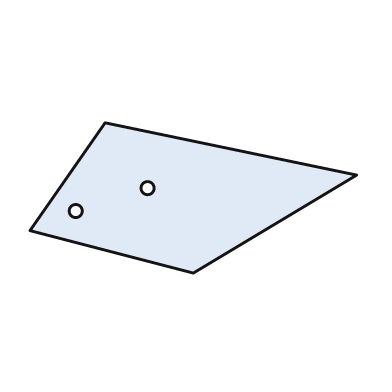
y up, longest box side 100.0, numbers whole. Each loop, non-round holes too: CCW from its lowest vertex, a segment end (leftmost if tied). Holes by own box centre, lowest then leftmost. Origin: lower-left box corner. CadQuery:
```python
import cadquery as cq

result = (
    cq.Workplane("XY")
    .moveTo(50.0, 0.0)
    .lineTo(100.0, 30.0)
    .lineTo(23.0, 46.0)
    .lineTo(0.0, 13.0)
    .close()
    .moveTo(14.0, 19.0)
    .circle(2.0)
    .moveTo(36.0, 26.0)
    .circle(2.0)
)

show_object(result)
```